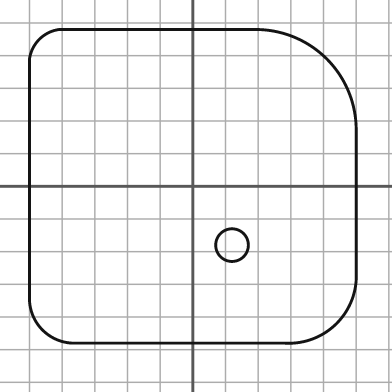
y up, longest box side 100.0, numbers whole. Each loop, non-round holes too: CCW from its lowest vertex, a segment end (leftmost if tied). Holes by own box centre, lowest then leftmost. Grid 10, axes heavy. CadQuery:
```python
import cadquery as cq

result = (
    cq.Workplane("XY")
    .moveTo(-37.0, -48.0)
    .lineTo(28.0, -48.0)
    .threePointArc((44.0, -42.0), (50.0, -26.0))
    .lineTo(50.0, 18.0)
    .threePointArc((41.0, 39.0), (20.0, 48.0))
    .lineTo(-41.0, 48.0)
    .threePointArc((-47.0, 45.0), (-50.0, 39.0))
    .lineTo(-50.0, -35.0)
    .threePointArc((-46.0, -44.0), (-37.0, -48.0))
    .close()
    .moveTo(12.0, -18.0)
    .circle(5.0)
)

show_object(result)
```